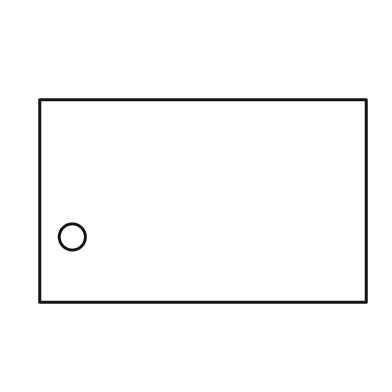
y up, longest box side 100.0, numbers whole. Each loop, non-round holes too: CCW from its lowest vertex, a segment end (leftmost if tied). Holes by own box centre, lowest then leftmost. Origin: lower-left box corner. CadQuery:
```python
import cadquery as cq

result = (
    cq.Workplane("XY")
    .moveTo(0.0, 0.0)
    .lineTo(100.0, 0.0)
    .lineTo(100.0, 62.0)
    .lineTo(0.0, 62.0)
    .close()
    .moveTo(10.0, 20.0)
    .circle(4.0)
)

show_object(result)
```